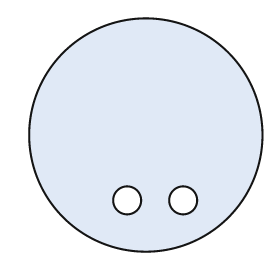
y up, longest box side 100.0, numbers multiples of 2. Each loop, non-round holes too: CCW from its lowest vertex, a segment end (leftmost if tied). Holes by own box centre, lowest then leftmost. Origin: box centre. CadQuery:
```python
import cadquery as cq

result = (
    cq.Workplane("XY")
    .moveTo(0.0, 0.0)
    .circle(50.0)
    .moveTo(-8.0, -28.0)
    .circle(6.0)
    .moveTo(16.0, -28.0)
    .circle(6.0)
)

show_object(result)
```